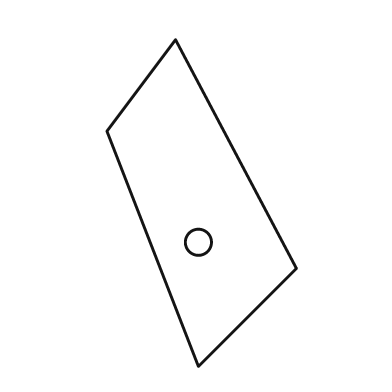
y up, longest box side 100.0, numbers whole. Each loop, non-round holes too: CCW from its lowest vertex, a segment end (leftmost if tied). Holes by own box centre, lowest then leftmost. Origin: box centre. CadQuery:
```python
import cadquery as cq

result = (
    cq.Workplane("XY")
    .moveTo(-1.0, -50.0)
    .lineTo(29.0, -20.0)
    .lineTo(-8.0, 50.0)
    .lineTo(-29.0, 22.0)
    .close()
    .moveTo(-1.0, -12.0)
    .circle(4.0)
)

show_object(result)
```